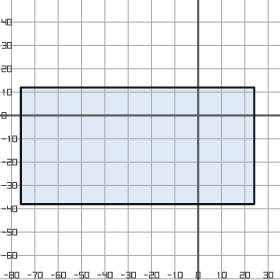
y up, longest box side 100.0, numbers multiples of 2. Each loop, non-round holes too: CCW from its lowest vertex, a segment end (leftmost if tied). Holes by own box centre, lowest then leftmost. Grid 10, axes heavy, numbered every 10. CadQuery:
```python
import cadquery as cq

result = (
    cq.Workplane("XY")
    .moveTo(-76.0, -38.0)
    .lineTo(24.0, -38.0)
    .lineTo(24.0, 12.0)
    .lineTo(-76.0, 12.0)
    .close()
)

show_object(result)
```